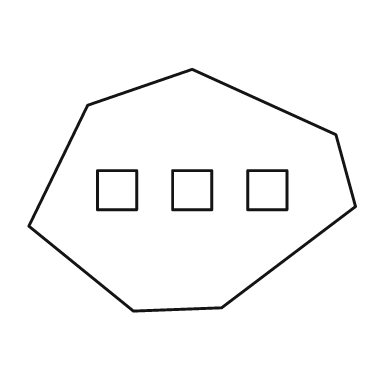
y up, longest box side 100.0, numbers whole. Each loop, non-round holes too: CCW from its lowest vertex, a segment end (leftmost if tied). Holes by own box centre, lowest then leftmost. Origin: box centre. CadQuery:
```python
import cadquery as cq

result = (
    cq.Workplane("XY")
    .moveTo(-18.0, -37.0)
    .lineTo(9.0, -36.0)
    .lineTo(50.0, -5.0)
    .lineTo(44.0, 17.0)
    .lineTo(0.0, 37.0)
    .lineTo(-32.0, 26.0)
    .lineTo(-50.0, -11.0)
    .close()
    .moveTo(-29.0, -6.0)
    .lineTo(-17.0, -6.0)
    .lineTo(-17.0, 6.0)
    .lineTo(-29.0, 6.0)
    .close()
    .moveTo(-6.0, -6.0)
    .lineTo(6.0, -6.0)
    .lineTo(6.0, 6.0)
    .lineTo(-6.0, 6.0)
    .close()
    .moveTo(17.0, -6.0)
    .lineTo(29.0, -6.0)
    .lineTo(29.0, 6.0)
    .lineTo(17.0, 6.0)
    .close()
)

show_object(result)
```